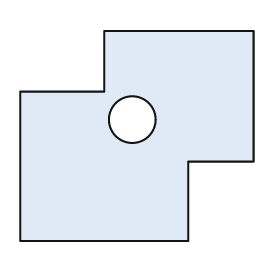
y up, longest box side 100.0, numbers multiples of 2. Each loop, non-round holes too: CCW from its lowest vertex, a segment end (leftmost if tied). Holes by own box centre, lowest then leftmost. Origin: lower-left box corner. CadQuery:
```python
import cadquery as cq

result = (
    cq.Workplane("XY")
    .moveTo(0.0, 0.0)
    .lineTo(72.0, 0.0)
    .lineTo(72.0, 34.0)
    .lineTo(100.0, 34.0)
    .lineTo(100.0, 90.0)
    .lineTo(36.0, 90.0)
    .lineTo(36.0, 64.0)
    .lineTo(0.0, 64.0)
    .close()
    .moveTo(48.0, 52.0)
    .circle(10.0)
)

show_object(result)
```